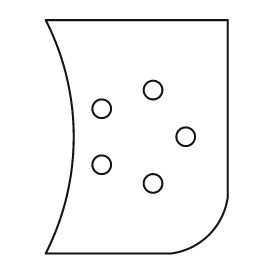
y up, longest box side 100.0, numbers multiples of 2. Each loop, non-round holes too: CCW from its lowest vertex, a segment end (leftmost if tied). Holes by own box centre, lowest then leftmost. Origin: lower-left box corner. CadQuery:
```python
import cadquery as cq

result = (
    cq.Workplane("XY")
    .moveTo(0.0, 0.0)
    .lineTo(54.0, 0.0)
    .threePointArc((70.0, 8.0), (78.0, 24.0))
    .lineTo(78.0, 100.0)
    .lineTo(0.0, 100.0)
    .threePointArc((12.0, 50.0), (0.0, 0.0))
    .close()
    .moveTo(46.0, 30.0)
    .circle(4.0)
    .moveTo(24.0, 38.0)
    .circle(4.0)
    .moveTo(60.0, 50.0)
    .circle(4.0)
    .moveTo(24.0, 62.0)
    .circle(4.0)
    .moveTo(46.0, 70.0)
    .circle(4.0)
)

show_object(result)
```